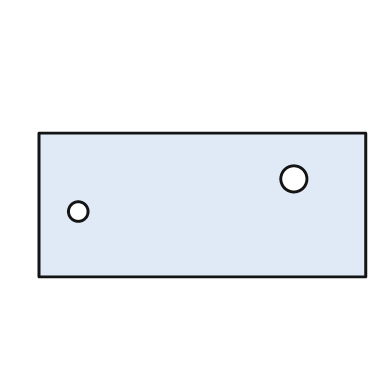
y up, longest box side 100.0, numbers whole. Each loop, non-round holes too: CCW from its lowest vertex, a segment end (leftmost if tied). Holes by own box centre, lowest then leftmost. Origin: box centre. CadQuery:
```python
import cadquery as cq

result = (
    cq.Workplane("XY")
    .moveTo(-50.0, -22.0)
    .lineTo(50.0, -22.0)
    .lineTo(50.0, 22.0)
    .lineTo(-50.0, 22.0)
    .close()
    .moveTo(-38.0, -2.0)
    .circle(3.0)
    .moveTo(28.0, 8.0)
    .circle(4.0)
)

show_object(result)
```